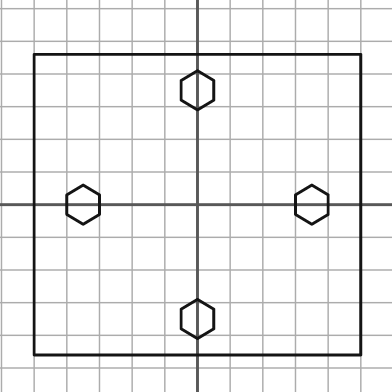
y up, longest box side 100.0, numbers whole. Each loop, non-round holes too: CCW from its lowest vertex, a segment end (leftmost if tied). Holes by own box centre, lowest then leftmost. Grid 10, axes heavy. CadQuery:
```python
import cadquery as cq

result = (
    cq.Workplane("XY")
    .moveTo(-50.0, -46.0)
    .lineTo(50.0, -46.0)
    .lineTo(50.0, 46.0)
    .lineTo(-50.0, 46.0)
    .close()
    .moveTo(0.0, -41.0)
    .lineTo(5.0, -38.0)
    .lineTo(5.0, -32.0)
    .lineTo(0.0, -29.0)
    .lineTo(-5.0, -32.0)
    .lineTo(-5.0, -38.0)
    .close()
    .moveTo(-35.0, -6.0)
    .lineTo(-30.0, -3.0)
    .lineTo(-30.0, 3.0)
    .lineTo(-35.0, 6.0)
    .lineTo(-40.0, 3.0)
    .lineTo(-40.0, -3.0)
    .close()
    .moveTo(35.0, -6.0)
    .lineTo(40.0, -3.0)
    .lineTo(40.0, 3.0)
    .lineTo(35.0, 6.0)
    .lineTo(30.0, 3.0)
    .lineTo(30.0, -3.0)
    .close()
    .moveTo(0.0, 29.0)
    .lineTo(5.0, 32.0)
    .lineTo(5.0, 38.0)
    .lineTo(0.0, 41.0)
    .lineTo(-5.0, 38.0)
    .lineTo(-5.0, 32.0)
    .close()
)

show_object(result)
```